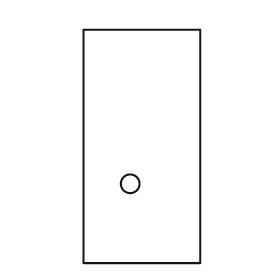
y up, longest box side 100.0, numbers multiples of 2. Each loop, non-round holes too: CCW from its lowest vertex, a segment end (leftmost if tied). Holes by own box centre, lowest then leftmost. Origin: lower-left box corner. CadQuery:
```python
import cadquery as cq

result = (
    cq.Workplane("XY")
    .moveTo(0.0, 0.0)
    .lineTo(50.0, 0.0)
    .lineTo(50.0, 100.0)
    .lineTo(0.0, 100.0)
    .close()
    .moveTo(20.0, 34.0)
    .circle(4.0)
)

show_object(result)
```